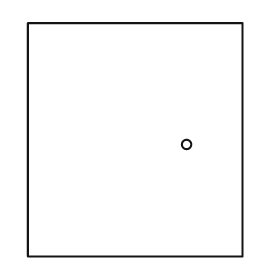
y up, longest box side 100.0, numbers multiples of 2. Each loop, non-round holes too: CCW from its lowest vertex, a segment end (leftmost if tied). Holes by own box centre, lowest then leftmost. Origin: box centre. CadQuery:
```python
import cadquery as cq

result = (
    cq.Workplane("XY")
    .moveTo(-46.0, -50.0)
    .lineTo(46.0, -50.0)
    .lineTo(46.0, 50.0)
    .lineTo(-46.0, 50.0)
    .close()
    .moveTo(22.0, -2.0)
    .circle(2.0)
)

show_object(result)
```